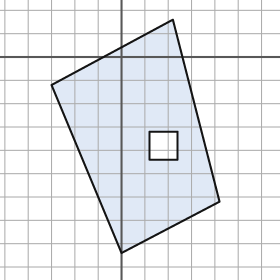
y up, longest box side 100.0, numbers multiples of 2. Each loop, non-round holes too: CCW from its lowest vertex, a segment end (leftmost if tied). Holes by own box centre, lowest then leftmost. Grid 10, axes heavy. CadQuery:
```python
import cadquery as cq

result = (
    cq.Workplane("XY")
    .moveTo(0.0, -84.0)
    .lineTo(42.0, -62.0)
    .lineTo(22.0, 16.0)
    .lineTo(-30.0, -12.0)
    .close()
    .moveTo(12.0, -44.0)
    .lineTo(24.0, -44.0)
    .lineTo(24.0, -32.0)
    .lineTo(12.0, -32.0)
    .close()
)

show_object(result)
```